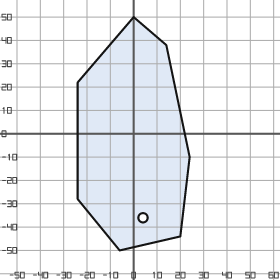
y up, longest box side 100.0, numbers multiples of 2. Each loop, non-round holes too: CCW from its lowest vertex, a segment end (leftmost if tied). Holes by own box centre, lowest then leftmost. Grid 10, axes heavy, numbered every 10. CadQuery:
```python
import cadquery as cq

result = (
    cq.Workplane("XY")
    .moveTo(-6.0, -50.0)
    .lineTo(20.0, -44.0)
    .lineTo(24.0, -10.0)
    .lineTo(14.0, 38.0)
    .lineTo(0.0, 50.0)
    .lineTo(-24.0, 22.0)
    .lineTo(-24.0, -28.0)
    .close()
    .moveTo(4.0, -36.0)
    .circle(2.0)
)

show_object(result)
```